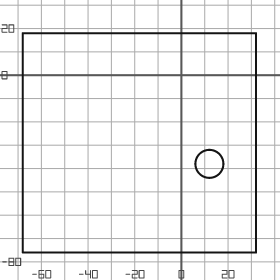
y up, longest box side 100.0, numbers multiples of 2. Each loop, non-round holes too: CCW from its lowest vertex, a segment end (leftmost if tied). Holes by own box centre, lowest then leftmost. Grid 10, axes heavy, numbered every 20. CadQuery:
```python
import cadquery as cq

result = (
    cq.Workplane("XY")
    .moveTo(-68.0, -76.0)
    .lineTo(32.0, -76.0)
    .lineTo(32.0, 18.0)
    .lineTo(-68.0, 18.0)
    .close()
    .moveTo(12.0, -38.0)
    .circle(6.0)
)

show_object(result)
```